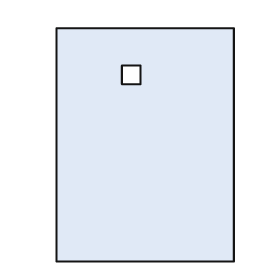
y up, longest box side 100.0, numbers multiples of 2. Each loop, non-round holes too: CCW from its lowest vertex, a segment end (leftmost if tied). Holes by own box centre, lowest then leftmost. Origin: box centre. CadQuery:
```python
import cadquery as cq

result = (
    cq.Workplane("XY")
    .moveTo(-38.0, -50.0)
    .lineTo(38.0, -50.0)
    .lineTo(38.0, 50.0)
    .lineTo(-38.0, 50.0)
    .close()
    .moveTo(-10.0, 26.0)
    .lineTo(-2.0, 26.0)
    .lineTo(-2.0, 34.0)
    .lineTo(-10.0, 34.0)
    .close()
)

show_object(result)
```